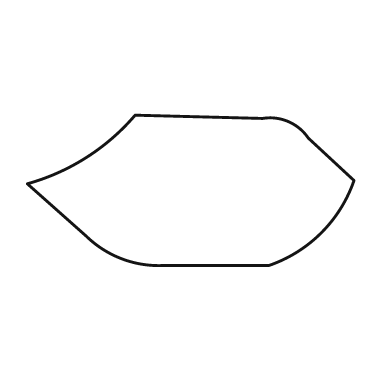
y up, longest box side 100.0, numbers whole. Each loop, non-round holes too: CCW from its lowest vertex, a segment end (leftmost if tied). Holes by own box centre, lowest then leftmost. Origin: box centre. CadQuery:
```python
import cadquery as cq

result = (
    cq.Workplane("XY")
    .moveTo(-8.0, -23.0)
    .lineTo(24.0, -23.0)
    .threePointArc((40.0, -13.0), (50.0, 3.0))
    .lineTo(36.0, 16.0)
    .threePointArc((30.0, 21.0), (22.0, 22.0))
    .lineTo(-17.0, 23.0)
    .threePointArc((-32.0, 10.0), (-50.0, 2.0))
    .lineTo(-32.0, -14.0)
    .threePointArc((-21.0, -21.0), (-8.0, -23.0))
    .close()
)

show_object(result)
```